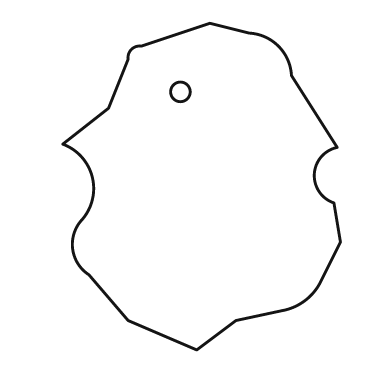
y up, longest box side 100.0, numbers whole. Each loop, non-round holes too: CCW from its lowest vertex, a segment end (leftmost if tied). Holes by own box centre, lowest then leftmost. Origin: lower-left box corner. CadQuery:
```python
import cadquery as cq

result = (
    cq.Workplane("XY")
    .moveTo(41.0, 0.0)
    .lineTo(53.0, 9.0)
    .lineTo(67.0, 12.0)
    .threePointArc((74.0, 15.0), (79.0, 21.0))
    .lineTo(85.0, 33.0)
    .lineTo(83.0, 45.0)
    .threePointArc((77.0, 54.0), (84.0, 62.0))
    .lineTo(70.0, 84.0)
    .threePointArc((66.0, 93.0), (57.0, 97.0))
    .lineTo(45.0, 100.0)
    .lineTo(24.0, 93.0)
    .threePointArc((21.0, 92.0), (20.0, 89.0))
    .lineTo(14.0, 74.0)
    .lineTo(0.0, 63.0)
    .threePointArc((9.0, 53.0), (6.0, 40.0))
    .threePointArc((3.0, 31.0), (8.0, 23.0))
    .lineTo(20.0, 9.0)
    .close()
    .moveTo(36.0, 79.0)
    .circle(3.0)
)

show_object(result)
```